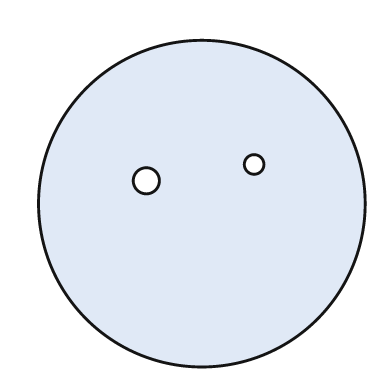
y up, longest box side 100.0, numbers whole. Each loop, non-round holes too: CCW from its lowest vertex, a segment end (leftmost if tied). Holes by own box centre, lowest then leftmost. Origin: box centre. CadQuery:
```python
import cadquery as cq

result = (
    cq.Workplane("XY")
    .moveTo(0.0, 0.0)
    .circle(50.0)
    .moveTo(-17.0, 7.0)
    .circle(4.0)
    .moveTo(16.0, 12.0)
    .circle(3.0)
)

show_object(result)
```